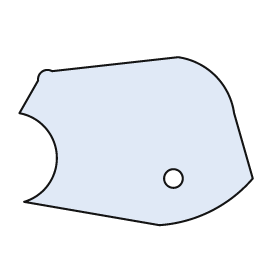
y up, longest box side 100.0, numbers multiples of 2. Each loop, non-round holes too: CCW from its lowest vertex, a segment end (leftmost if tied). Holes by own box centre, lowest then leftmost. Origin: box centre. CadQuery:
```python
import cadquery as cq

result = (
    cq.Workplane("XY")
    .moveTo(10.0, -36.0)
    .threePointArc((32.0, -30.0), (50.0, -16.0))
    .lineTo(42.0, 12.0)
    .threePointArc((34.0, 28.0), (18.0, 36.0))
    .lineTo(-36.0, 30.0)
    .threePointArc((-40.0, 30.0), (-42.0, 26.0))
    .lineTo(-50.0, 12.0)
    .threePointArc((-34.0, -6.0), (-48.0, -26.0))
    .close()
    .moveTo(16.0, -16.0)
    .circle(4.0)
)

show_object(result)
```